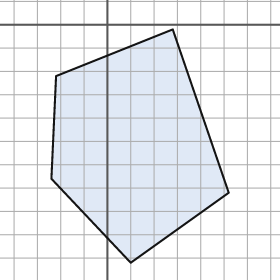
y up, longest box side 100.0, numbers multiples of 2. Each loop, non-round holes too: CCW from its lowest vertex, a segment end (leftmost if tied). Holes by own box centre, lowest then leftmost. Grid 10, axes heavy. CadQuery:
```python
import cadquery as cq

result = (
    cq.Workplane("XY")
    .moveTo(10.0, -102.0)
    .lineTo(52.0, -72.0)
    .lineTo(28.0, -2.0)
    .lineTo(-22.0, -22.0)
    .lineTo(-24.0, -66.0)
    .close()
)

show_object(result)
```